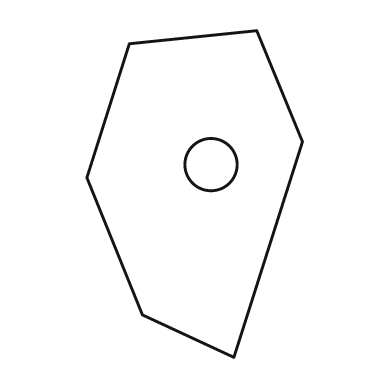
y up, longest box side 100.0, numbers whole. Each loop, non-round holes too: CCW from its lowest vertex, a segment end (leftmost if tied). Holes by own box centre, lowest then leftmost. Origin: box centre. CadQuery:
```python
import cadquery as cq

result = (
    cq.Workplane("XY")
    .moveTo(12.0, -50.0)
    .lineTo(33.0, 16.0)
    .lineTo(19.0, 50.0)
    .lineTo(-20.0, 46.0)
    .lineTo(-33.0, 5.0)
    .lineTo(-16.0, -37.0)
    .close()
    .moveTo(5.0, 9.0)
    .circle(8.0)
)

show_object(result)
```